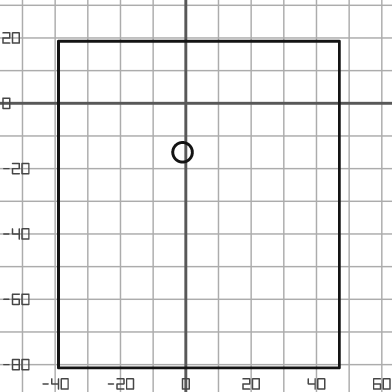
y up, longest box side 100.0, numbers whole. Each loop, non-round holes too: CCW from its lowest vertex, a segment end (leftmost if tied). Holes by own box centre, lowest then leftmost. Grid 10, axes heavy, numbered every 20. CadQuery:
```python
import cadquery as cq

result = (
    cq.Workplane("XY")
    .moveTo(-39.0, -81.0)
    .lineTo(47.0, -81.0)
    .lineTo(47.0, 19.0)
    .lineTo(-39.0, 19.0)
    .close()
    .moveTo(-1.0, -15.0)
    .circle(3.0)
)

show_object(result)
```